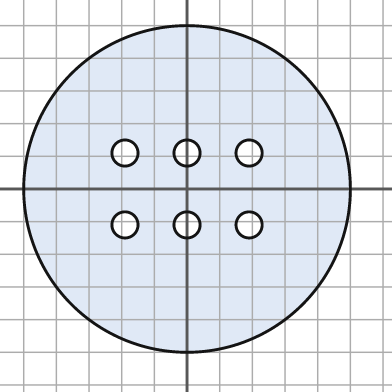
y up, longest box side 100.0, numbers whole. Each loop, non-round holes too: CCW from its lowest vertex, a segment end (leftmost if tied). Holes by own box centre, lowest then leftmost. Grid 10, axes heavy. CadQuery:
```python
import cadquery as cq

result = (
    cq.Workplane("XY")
    .moveTo(0.0, 0.0)
    .circle(50.0)
    .moveTo(-19.0, -11.0)
    .circle(4.0)
    .moveTo(0.0, -11.0)
    .circle(4.0)
    .moveTo(19.0, -11.0)
    .circle(4.0)
    .moveTo(-19.0, 11.0)
    .circle(4.0)
    .moveTo(0.0, 11.0)
    .circle(4.0)
    .moveTo(19.0, 11.0)
    .circle(4.0)
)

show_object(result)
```